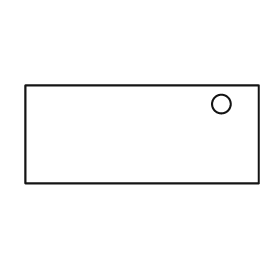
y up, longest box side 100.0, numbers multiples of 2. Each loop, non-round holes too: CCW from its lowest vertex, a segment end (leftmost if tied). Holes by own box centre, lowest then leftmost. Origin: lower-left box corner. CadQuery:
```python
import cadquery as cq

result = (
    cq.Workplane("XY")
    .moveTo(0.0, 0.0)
    .lineTo(100.0, 0.0)
    .lineTo(100.0, 42.0)
    .lineTo(0.0, 42.0)
    .close()
    .moveTo(84.0, 34.0)
    .circle(4.0)
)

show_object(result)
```